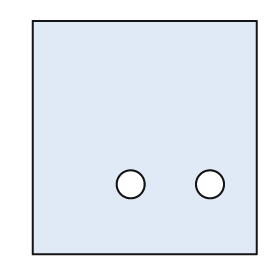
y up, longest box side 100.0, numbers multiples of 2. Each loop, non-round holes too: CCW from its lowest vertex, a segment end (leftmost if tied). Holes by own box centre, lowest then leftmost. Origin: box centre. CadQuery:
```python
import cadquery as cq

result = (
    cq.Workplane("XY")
    .moveTo(-48.0, -50.0)
    .lineTo(48.0, -50.0)
    .lineTo(48.0, 50.0)
    .lineTo(-48.0, 50.0)
    .close()
    .moveTo(-6.0, -20.0)
    .circle(6.0)
    .moveTo(28.0, -20.0)
    .circle(6.0)
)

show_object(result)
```